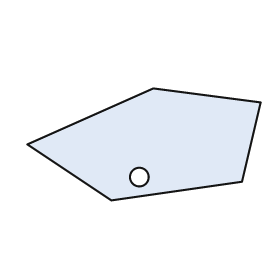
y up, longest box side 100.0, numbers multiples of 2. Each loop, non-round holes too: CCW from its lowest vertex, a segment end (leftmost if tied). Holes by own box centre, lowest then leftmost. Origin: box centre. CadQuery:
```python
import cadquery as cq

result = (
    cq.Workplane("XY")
    .moveTo(-14.0, -24.0)
    .lineTo(42.0, -16.0)
    .lineTo(50.0, 18.0)
    .lineTo(4.0, 24.0)
    .lineTo(-50.0, 0.0)
    .close()
    .moveTo(-2.0, -14.0)
    .circle(4.0)
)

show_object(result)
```